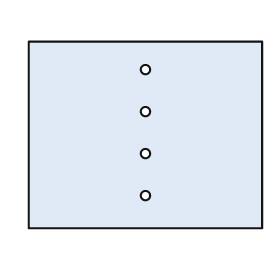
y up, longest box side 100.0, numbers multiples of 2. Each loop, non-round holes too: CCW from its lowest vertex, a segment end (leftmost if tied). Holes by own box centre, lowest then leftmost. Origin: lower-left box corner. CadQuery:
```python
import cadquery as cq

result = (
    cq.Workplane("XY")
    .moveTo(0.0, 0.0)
    .lineTo(100.0, 0.0)
    .lineTo(100.0, 80.0)
    .lineTo(0.0, 80.0)
    .close()
    .moveTo(50.0, 14.0)
    .circle(2.0)
    .moveTo(50.0, 32.0)
    .circle(2.0)
    .moveTo(50.0, 50.0)
    .circle(2.0)
    .moveTo(50.0, 68.0)
    .circle(2.0)
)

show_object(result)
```